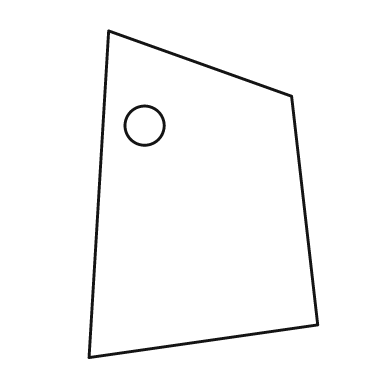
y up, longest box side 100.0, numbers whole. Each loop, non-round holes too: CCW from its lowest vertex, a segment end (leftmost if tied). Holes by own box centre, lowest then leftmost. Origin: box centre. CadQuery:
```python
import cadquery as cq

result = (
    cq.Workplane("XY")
    .moveTo(-35.0, -50.0)
    .lineTo(35.0, -40.0)
    .lineTo(27.0, 30.0)
    .lineTo(-29.0, 50.0)
    .close()
    .moveTo(-18.0, 21.0)
    .circle(6.0)
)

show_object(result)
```